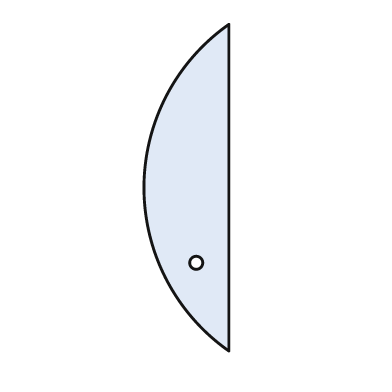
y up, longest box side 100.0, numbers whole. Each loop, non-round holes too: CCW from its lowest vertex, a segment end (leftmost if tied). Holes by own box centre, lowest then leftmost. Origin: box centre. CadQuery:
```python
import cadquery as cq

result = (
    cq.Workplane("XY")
    .moveTo(13.0, -50.0)
    .lineTo(13.0, 50.0)
    .threePointArc((-13.0, 0.0), (13.0, -50.0))
    .close()
    .moveTo(3.0, -23.0)
    .circle(2.0)
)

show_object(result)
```